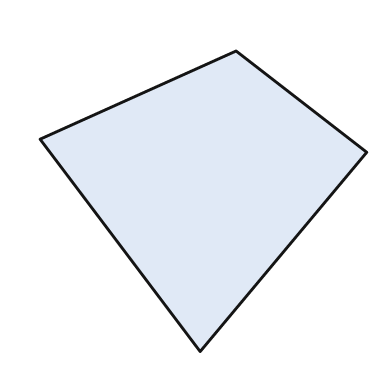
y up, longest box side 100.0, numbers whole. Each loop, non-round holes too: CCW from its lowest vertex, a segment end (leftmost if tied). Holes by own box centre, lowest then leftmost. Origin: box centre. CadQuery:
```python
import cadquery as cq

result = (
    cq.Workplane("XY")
    .moveTo(-1.0, -46.0)
    .lineTo(50.0, 15.0)
    .lineTo(10.0, 46.0)
    .lineTo(-50.0, 19.0)
    .close()
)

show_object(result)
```